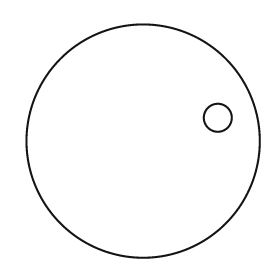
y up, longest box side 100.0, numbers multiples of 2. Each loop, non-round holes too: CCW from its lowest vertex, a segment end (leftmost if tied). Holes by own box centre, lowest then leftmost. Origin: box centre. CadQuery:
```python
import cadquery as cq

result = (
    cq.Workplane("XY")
    .moveTo(0.0, 0.0)
    .circle(50.0)
    .moveTo(32.0, 10.0)
    .circle(6.0)
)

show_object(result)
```